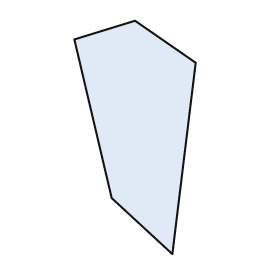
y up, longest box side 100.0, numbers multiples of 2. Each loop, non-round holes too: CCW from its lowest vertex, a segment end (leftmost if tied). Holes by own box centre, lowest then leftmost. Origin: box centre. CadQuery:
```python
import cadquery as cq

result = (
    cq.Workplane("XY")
    .moveTo(16.0, -50.0)
    .lineTo(26.0, 32.0)
    .lineTo(0.0, 50.0)
    .lineTo(-26.0, 42.0)
    .lineTo(-10.0, -26.0)
    .close()
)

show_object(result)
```